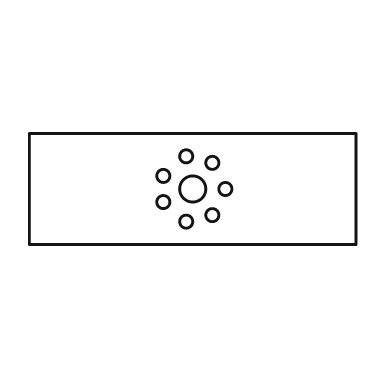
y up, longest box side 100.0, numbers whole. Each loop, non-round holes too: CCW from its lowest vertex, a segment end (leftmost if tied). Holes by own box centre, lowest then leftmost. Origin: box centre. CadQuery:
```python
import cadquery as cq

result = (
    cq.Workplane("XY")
    .moveTo(-50.0, -17.0)
    .lineTo(50.0, -17.0)
    .lineTo(50.0, 17.0)
    .lineTo(-50.0, 17.0)
    .close()
    .moveTo(-2.0, -10.0)
    .circle(2.0)
    .moveTo(6.0, -8.0)
    .circle(2.0)
    .moveTo(-9.0, -4.0)
    .circle(2.0)
    .moveTo(0.0, 0.0)
    .circle(4.0)
    .moveTo(10.0, 0.0)
    .circle(2.0)
    .moveTo(-9.0, 4.0)
    .circle(2.0)
    .moveTo(6.0, 8.0)
    .circle(2.0)
    .moveTo(-2.0, 10.0)
    .circle(2.0)
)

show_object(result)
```